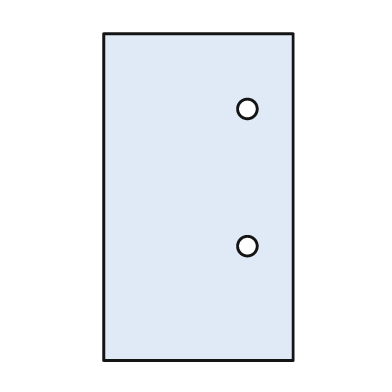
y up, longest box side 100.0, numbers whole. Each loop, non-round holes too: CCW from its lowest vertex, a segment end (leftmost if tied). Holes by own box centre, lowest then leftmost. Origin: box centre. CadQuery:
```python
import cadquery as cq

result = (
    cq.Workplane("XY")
    .moveTo(-29.0, -50.0)
    .lineTo(29.0, -50.0)
    .lineTo(29.0, 50.0)
    .lineTo(-29.0, 50.0)
    .close()
    .moveTo(15.0, -15.0)
    .circle(3.0)
    .moveTo(15.0, 27.0)
    .circle(3.0)
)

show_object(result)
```